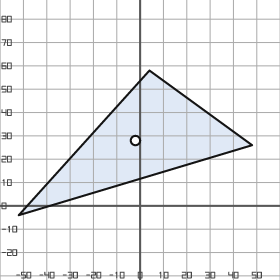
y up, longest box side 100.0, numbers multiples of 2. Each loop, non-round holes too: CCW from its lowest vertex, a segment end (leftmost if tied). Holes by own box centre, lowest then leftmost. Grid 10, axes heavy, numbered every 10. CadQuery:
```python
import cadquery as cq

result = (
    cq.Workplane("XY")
    .moveTo(-52.0, -4.0)
    .lineTo(48.0, 26.0)
    .lineTo(4.0, 58.0)
    .close()
    .moveTo(-2.0, 28.0)
    .circle(2.0)
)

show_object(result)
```